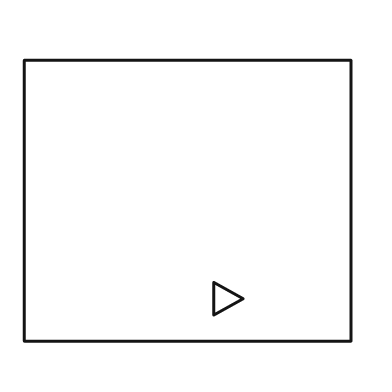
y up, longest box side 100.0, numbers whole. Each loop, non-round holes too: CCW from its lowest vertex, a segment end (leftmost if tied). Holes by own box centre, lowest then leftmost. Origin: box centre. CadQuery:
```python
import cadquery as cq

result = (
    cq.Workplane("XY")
    .moveTo(-50.0, -43.0)
    .lineTo(50.0, -43.0)
    .lineTo(50.0, 43.0)
    .lineTo(-50.0, 43.0)
    .close()
    .moveTo(8.0, -35.0)
    .lineTo(17.0, -30.0)
    .lineTo(8.0, -25.0)
    .close()
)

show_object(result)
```